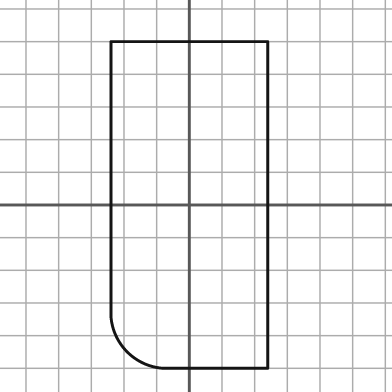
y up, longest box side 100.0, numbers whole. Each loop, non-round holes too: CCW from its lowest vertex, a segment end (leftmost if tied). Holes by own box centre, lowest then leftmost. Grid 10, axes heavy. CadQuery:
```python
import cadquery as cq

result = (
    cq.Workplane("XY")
    .moveTo(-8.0, -50.0)
    .lineTo(24.0, -50.0)
    .lineTo(24.0, 50.0)
    .lineTo(-24.0, 50.0)
    .lineTo(-24.0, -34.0)
    .threePointArc((-19.0, -45.0), (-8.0, -50.0))
    .close()
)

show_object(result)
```